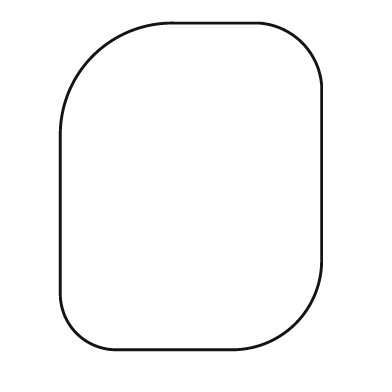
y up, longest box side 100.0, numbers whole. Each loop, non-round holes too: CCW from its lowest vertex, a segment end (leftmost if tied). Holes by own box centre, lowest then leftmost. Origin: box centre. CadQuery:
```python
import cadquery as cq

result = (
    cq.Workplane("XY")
    .moveTo(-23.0, -50.0)
    .lineTo(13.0, -50.0)
    .threePointArc((32.0, -42.0), (40.0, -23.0))
    .lineTo(40.0, 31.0)
    .threePointArc((34.0, 44.0), (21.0, 50.0))
    .lineTo(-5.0, 50.0)
    .threePointArc((-30.0, 40.0), (-40.0, 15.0))
    .lineTo(-40.0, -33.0)
    .threePointArc((-35.0, -45.0), (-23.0, -50.0))
    .close()
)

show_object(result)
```